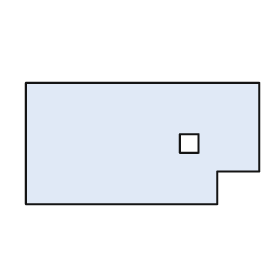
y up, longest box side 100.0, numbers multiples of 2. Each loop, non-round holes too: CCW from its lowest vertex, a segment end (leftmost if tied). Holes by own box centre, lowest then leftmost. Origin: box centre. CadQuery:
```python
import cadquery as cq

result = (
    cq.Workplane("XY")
    .moveTo(-50.0, -26.0)
    .lineTo(32.0, -26.0)
    .lineTo(32.0, -12.0)
    .lineTo(50.0, -12.0)
    .lineTo(50.0, 26.0)
    .lineTo(-50.0, 26.0)
    .close()
    .moveTo(16.0, -4.0)
    .lineTo(24.0, -4.0)
    .lineTo(24.0, 4.0)
    .lineTo(16.0, 4.0)
    .close()
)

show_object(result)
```